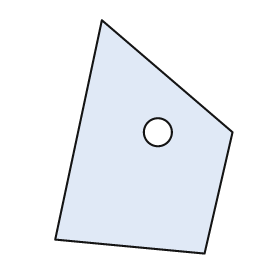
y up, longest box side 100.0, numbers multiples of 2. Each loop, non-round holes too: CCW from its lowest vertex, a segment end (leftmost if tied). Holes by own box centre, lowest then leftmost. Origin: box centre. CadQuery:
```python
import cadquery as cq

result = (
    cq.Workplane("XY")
    .moveTo(26.0, -50.0)
    .lineTo(38.0, 2.0)
    .lineTo(-18.0, 50.0)
    .lineTo(-38.0, -44.0)
    .close()
    .moveTo(6.0, 2.0)
    .circle(6.0)
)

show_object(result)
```